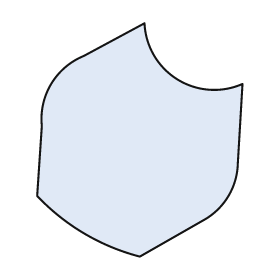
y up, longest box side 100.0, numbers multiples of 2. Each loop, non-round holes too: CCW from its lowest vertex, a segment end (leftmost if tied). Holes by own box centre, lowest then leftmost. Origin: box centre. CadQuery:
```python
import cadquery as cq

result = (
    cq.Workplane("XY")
    .moveTo(0.0, -50.0)
    .lineTo(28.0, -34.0)
    .threePointArc((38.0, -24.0), (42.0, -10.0))
    .lineTo(44.0, 24.0)
    .threePointArc((16.0, 26.0), (2.0, 50.0))
    .lineTo(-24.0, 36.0)
    .threePointArc((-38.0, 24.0), (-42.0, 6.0))
    .lineTo(-44.0, -24.0)
    .threePointArc((-24.0, -40.0), (0.0, -50.0))
    .close()
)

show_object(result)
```